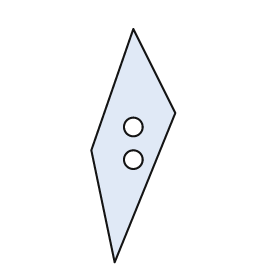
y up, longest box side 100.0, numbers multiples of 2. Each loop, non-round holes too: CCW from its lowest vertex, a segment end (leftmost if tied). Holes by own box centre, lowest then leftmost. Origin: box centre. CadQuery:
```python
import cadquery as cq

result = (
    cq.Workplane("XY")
    .moveTo(-8.0, -50.0)
    .lineTo(18.0, 14.0)
    .lineTo(0.0, 50.0)
    .lineTo(-18.0, -2.0)
    .close()
    .moveTo(0.0, -6.0)
    .circle(4.0)
    .moveTo(0.0, 8.0)
    .circle(4.0)
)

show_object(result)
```